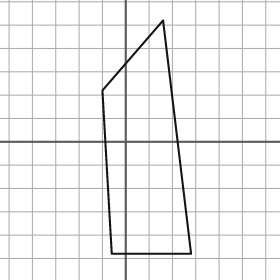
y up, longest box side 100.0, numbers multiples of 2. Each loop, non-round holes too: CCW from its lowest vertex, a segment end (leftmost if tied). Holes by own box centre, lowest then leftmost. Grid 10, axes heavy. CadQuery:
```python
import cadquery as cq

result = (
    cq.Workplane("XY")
    .moveTo(-6.0, -48.0)
    .lineTo(28.0, -48.0)
    .lineTo(16.0, 52.0)
    .lineTo(-10.0, 22.0)
    .close()
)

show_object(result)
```